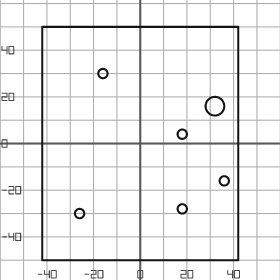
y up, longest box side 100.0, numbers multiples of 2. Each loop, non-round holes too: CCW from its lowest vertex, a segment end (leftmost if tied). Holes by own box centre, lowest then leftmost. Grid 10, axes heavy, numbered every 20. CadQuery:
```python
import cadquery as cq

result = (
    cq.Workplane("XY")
    .moveTo(-42.0, -50.0)
    .lineTo(42.0, -50.0)
    .lineTo(42.0, 50.0)
    .lineTo(-42.0, 50.0)
    .close()
    .moveTo(-26.0, -30.0)
    .circle(2.0)
    .moveTo(18.0, -28.0)
    .circle(2.0)
    .moveTo(36.0, -16.0)
    .circle(2.0)
    .moveTo(18.0, 4.0)
    .circle(2.0)
    .moveTo(32.0, 16.0)
    .circle(4.0)
    .moveTo(-16.0, 30.0)
    .circle(2.0)
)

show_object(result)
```